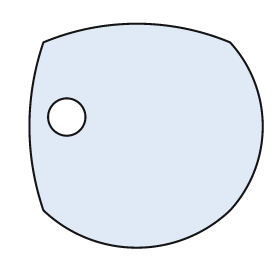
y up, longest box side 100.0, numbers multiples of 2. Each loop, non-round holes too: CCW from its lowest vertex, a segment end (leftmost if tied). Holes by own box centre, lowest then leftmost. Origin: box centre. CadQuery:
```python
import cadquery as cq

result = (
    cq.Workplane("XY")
    .moveTo(-44.0, -32.0)
    .threePointArc((-4.0, -48.0), (36.0, -32.0))
    .threePointArc((50.0, 4.0), (36.0, 40.0))
    .threePointArc((-4.0, 48.0), (-44.0, 40.0))
    .threePointArc((-50.0, 4.0), (-44.0, -32.0))
    .close()
    .moveTo(-34.0, 8.0)
    .circle(8.0)
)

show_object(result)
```